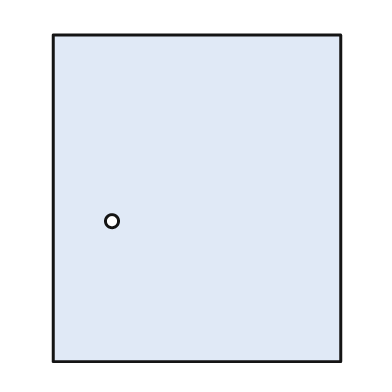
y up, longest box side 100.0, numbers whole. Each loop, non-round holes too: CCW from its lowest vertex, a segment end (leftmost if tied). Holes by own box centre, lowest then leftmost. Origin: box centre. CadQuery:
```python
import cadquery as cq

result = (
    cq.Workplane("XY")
    .moveTo(-44.0, -50.0)
    .lineTo(44.0, -50.0)
    .lineTo(44.0, 50.0)
    .lineTo(-44.0, 50.0)
    .close()
    .moveTo(-26.0, -7.0)
    .circle(2.0)
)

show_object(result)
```